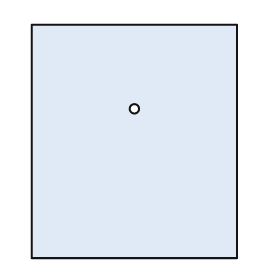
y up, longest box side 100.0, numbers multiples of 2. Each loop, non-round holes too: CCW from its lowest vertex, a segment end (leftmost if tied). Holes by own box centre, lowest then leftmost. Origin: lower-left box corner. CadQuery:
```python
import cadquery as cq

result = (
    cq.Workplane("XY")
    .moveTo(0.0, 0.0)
    .lineTo(88.0, 0.0)
    .lineTo(88.0, 100.0)
    .lineTo(0.0, 100.0)
    .close()
    .moveTo(44.0, 64.0)
    .circle(2.0)
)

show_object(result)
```